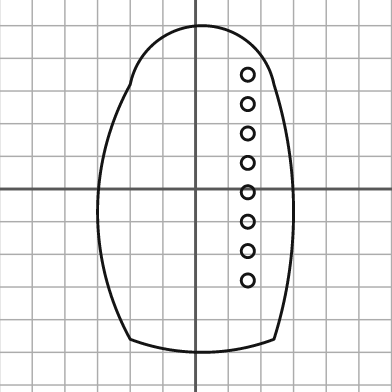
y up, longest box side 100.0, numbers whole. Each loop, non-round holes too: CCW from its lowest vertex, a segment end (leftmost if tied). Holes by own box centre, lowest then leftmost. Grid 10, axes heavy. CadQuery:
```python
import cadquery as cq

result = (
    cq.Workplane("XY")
    .moveTo(-20.0, -46.0)
    .threePointArc((2.0, -50.0), (24.0, -46.0))
    .threePointArc((30.0, -7.0), (24.0, 32.0))
    .threePointArc((2.0, 50.0), (-20.0, 32.0))
    .threePointArc((-30.0, -7.0), (-20.0, -46.0))
    .close()
    .moveTo(16.0, -28.0)
    .circle(2.0)
    .moveTo(16.0, -19.0)
    .circle(2.0)
    .moveTo(16.0, -10.0)
    .circle(2.0)
    .moveTo(16.0, -1.0)
    .circle(2.0)
    .moveTo(16.0, 8.0)
    .circle(2.0)
    .moveTo(16.0, 17.0)
    .circle(2.0)
    .moveTo(16.0, 26.0)
    .circle(2.0)
    .moveTo(16.0, 35.0)
    .circle(2.0)
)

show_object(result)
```